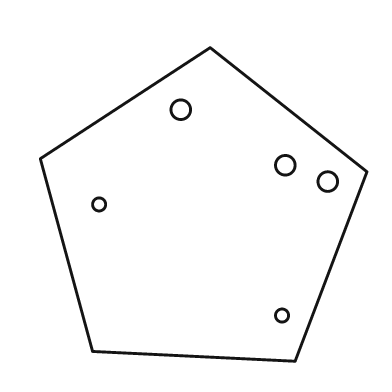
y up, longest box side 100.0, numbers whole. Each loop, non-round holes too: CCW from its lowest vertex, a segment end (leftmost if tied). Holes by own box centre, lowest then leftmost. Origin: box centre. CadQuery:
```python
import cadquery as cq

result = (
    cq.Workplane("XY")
    .moveTo(28.0, -48.0)
    .lineTo(50.0, 10.0)
    .lineTo(2.0, 48.0)
    .lineTo(-50.0, 14.0)
    .lineTo(-34.0, -45.0)
    .close()
    .moveTo(24.0, -34.0)
    .circle(2.0)
    .moveTo(-32.0, 0.0)
    .circle(2.0)
    .moveTo(38.0, 7.0)
    .circle(3.0)
    .moveTo(25.0, 12.0)
    .circle(3.0)
    .moveTo(-7.0, 29.0)
    .circle(3.0)
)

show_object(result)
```